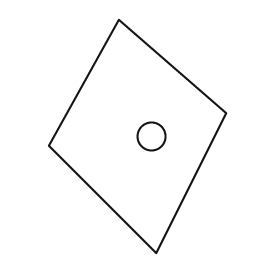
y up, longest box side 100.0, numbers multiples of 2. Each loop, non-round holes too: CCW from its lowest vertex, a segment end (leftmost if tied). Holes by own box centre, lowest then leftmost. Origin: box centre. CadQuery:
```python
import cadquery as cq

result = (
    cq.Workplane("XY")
    .moveTo(8.0, -50.0)
    .lineTo(38.0, 10.0)
    .lineTo(-8.0, 50.0)
    .lineTo(-38.0, -4.0)
    .close()
    .moveTo(6.0, 0.0)
    .circle(6.0)
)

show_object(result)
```